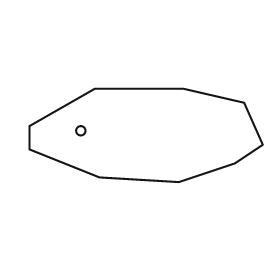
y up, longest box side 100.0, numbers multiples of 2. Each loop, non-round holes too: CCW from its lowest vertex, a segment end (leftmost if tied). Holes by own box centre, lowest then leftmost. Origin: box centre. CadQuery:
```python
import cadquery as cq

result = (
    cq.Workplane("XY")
    .moveTo(14.0, -20.0)
    .lineTo(38.0, -12.0)
    .lineTo(50.0, -4.0)
    .lineTo(42.0, 14.0)
    .lineTo(16.0, 20.0)
    .lineTo(-22.0, 20.0)
    .lineTo(-50.0, 4.0)
    .lineTo(-50.0, -6.0)
    .lineTo(-20.0, -18.0)
    .close()
    .moveTo(-28.0, 2.0)
    .circle(2.0)
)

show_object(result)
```